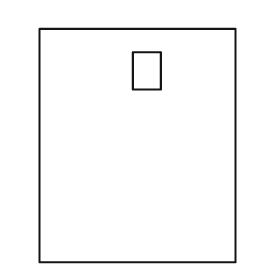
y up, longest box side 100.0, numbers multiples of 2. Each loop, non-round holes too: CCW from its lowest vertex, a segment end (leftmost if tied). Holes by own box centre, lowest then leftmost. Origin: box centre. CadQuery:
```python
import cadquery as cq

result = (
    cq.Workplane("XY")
    .moveTo(-42.0, -50.0)
    .lineTo(42.0, -50.0)
    .lineTo(42.0, 50.0)
    .lineTo(-42.0, 50.0)
    .close()
    .moveTo(-2.0, 24.0)
    .lineTo(10.0, 24.0)
    .lineTo(10.0, 40.0)
    .lineTo(-2.0, 40.0)
    .close()
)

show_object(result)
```